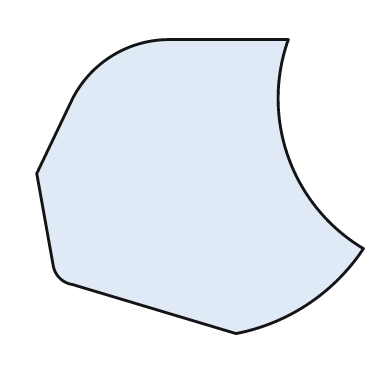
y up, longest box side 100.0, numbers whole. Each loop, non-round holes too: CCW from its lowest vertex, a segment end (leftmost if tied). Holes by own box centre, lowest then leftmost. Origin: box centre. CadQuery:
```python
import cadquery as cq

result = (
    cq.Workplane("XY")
    .moveTo(11.0, -45.0)
    .threePointArc((33.0, -36.0), (50.0, -19.0))
    .threePointArc((27.0, 9.0), (27.0, 45.0))
    .lineTo(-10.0, 45.0)
    .threePointArc((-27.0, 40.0), (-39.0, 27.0))
    .lineTo(-50.0, 4.0)
    .lineTo(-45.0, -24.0)
    .threePointArc((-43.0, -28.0), (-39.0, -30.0))
    .close()
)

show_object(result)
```